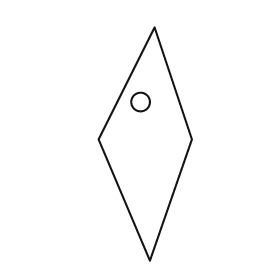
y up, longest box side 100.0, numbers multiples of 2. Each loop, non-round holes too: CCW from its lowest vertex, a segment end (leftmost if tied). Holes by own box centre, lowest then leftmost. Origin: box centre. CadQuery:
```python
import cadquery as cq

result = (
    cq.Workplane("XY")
    .moveTo(2.0, -50.0)
    .lineTo(20.0, 2.0)
    .lineTo(4.0, 50.0)
    .lineTo(-20.0, 2.0)
    .close()
    .moveTo(-2.0, 18.0)
    .circle(4.0)
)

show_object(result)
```